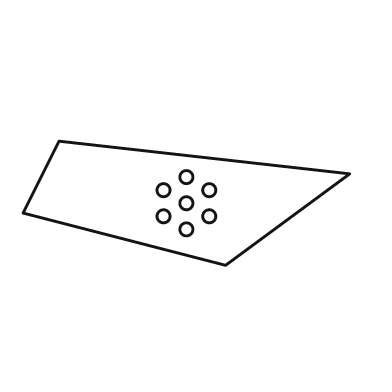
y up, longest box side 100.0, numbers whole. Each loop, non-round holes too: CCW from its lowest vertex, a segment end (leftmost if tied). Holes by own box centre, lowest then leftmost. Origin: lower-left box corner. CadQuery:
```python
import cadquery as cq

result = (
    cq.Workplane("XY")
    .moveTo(62.0, 0.0)
    .lineTo(100.0, 28.0)
    .lineTo(11.0, 38.0)
    .lineTo(0.0, 16.0)
    .close()
    .moveTo(50.0, 11.0)
    .circle(2.0)
    .moveTo(43.0, 15.0)
    .circle(2.0)
    .moveTo(57.0, 15.0)
    .circle(2.0)
    .moveTo(50.0, 19.0)
    .circle(2.0)
    .moveTo(43.0, 23.0)
    .circle(2.0)
    .moveTo(57.0, 23.0)
    .circle(2.0)
    .moveTo(50.0, 27.0)
    .circle(2.0)
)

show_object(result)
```